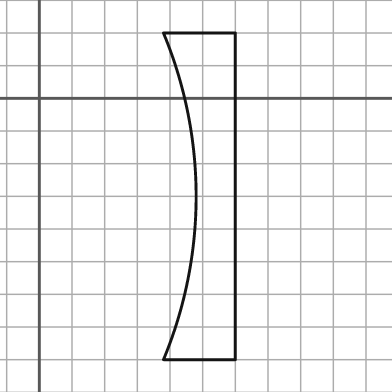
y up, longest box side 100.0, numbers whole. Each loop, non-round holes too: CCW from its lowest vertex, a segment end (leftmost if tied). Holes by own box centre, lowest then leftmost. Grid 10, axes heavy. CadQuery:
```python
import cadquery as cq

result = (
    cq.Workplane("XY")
    .moveTo(38.0, -80.0)
    .lineTo(60.0, -80.0)
    .lineTo(60.0, 20.0)
    .lineTo(38.0, 20.0)
    .threePointArc((48.0, -30.0), (38.0, -80.0))
    .close()
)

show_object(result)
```